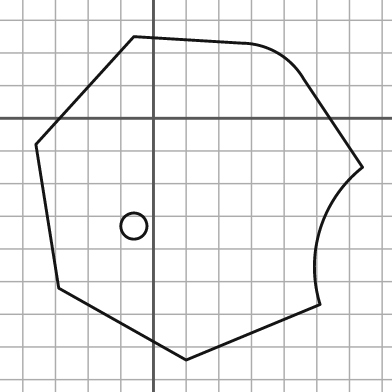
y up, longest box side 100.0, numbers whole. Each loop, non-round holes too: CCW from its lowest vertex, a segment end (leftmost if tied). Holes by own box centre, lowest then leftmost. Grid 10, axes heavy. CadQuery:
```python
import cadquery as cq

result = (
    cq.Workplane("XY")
    .moveTo(10.0, -74.0)
    .lineTo(51.0, -57.0)
    .threePointArc((51.0, -34.0), (64.0, -15.0))
    .lineTo(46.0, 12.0)
    .threePointArc((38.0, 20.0), (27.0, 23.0))
    .lineTo(-6.0, 25.0)
    .lineTo(-36.0, -8.0)
    .lineTo(-29.0, -52.0)
    .close()
    .moveTo(-6.0, -33.0)
    .circle(4.0)
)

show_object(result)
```